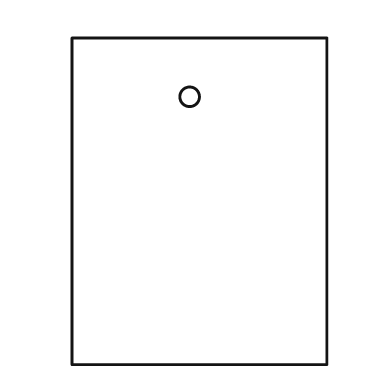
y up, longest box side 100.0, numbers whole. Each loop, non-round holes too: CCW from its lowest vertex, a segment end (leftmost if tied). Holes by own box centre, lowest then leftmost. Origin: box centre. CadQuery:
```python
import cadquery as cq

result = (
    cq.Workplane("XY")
    .moveTo(-39.0, -50.0)
    .lineTo(39.0, -50.0)
    .lineTo(39.0, 50.0)
    .lineTo(-39.0, 50.0)
    .close()
    .moveTo(-3.0, 32.0)
    .circle(3.0)
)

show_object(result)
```